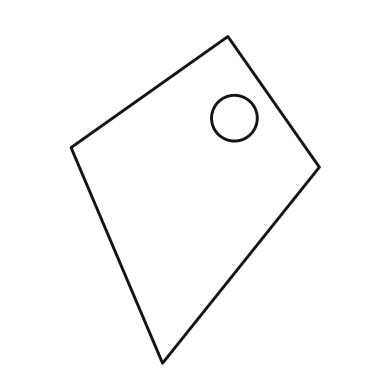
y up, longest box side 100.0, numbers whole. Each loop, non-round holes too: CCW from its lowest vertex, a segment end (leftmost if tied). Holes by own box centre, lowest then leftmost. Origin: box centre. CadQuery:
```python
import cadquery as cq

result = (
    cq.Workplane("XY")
    .moveTo(-10.0, -50.0)
    .lineTo(38.0, 10.0)
    .lineTo(10.0, 50.0)
    .lineTo(-38.0, 16.0)
    .close()
    .moveTo(12.0, 25.0)
    .circle(7.0)
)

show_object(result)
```